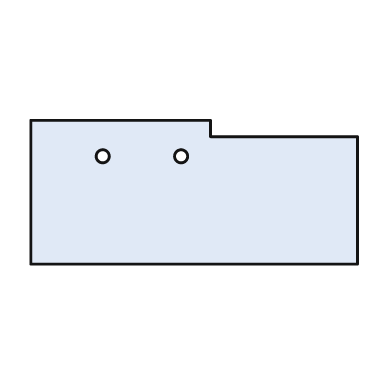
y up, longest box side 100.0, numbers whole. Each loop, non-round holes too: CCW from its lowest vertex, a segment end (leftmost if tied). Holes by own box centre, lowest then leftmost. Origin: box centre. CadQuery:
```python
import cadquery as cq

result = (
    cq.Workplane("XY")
    .moveTo(-50.0, -22.0)
    .lineTo(50.0, -22.0)
    .lineTo(50.0, 17.0)
    .lineTo(5.0, 17.0)
    .lineTo(5.0, 22.0)
    .lineTo(-50.0, 22.0)
    .close()
    .moveTo(-28.0, 11.0)
    .circle(2.0)
    .moveTo(-4.0, 11.0)
    .circle(2.0)
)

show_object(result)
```